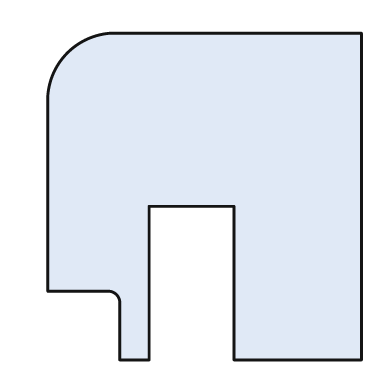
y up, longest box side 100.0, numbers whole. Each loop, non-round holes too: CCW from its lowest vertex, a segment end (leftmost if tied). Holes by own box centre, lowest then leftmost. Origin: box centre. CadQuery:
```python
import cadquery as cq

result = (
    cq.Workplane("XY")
    .moveTo(-26.0, -50.0)
    .lineTo(-17.0, -50.0)
    .lineTo(-17.0, -3.0)
    .lineTo(9.0, -3.0)
    .lineTo(9.0, -50.0)
    .lineTo(48.0, -50.0)
    .lineTo(48.0, 50.0)
    .lineTo(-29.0, 50.0)
    .threePointArc((-42.0, 44.0), (-48.0, 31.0))
    .lineTo(-48.0, -29.0)
    .lineTo(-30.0, -29.0)
    .threePointArc((-27.0, -30.0), (-26.0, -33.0))
    .close()
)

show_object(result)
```